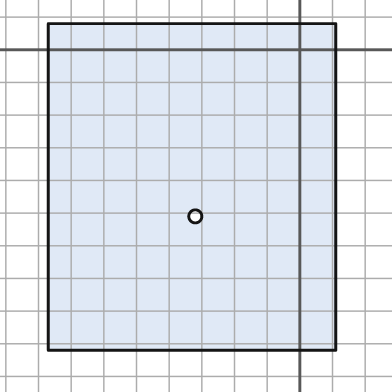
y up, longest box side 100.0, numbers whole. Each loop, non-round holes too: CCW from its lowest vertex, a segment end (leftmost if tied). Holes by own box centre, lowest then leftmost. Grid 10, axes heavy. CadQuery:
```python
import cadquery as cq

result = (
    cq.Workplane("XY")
    .moveTo(-77.0, -92.0)
    .lineTo(11.0, -92.0)
    .lineTo(11.0, 8.0)
    .lineTo(-77.0, 8.0)
    .close()
    .moveTo(-32.0, -51.0)
    .circle(2.0)
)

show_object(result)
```